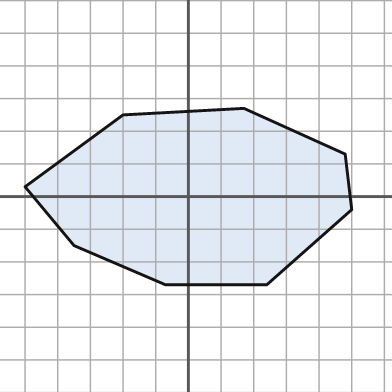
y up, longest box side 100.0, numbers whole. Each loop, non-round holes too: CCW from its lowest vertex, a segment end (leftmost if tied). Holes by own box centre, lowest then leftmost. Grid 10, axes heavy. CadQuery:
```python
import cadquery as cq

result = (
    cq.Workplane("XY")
    .moveTo(-7.0, -27.0)
    .lineTo(24.0, -27.0)
    .lineTo(50.0, -4.0)
    .lineTo(48.0, 13.0)
    .lineTo(17.0, 27.0)
    .lineTo(-20.0, 25.0)
    .lineTo(-50.0, 3.0)
    .lineTo(-35.0, -15.0)
    .close()
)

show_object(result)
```